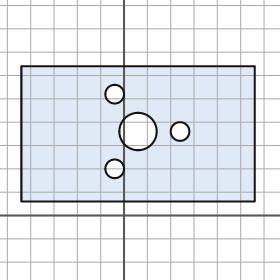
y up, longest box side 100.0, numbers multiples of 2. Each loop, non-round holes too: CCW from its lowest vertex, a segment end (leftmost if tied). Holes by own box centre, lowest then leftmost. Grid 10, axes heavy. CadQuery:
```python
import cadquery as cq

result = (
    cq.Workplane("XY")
    .moveTo(-44.0, 6.0)
    .lineTo(56.0, 6.0)
    .lineTo(56.0, 64.0)
    .lineTo(-44.0, 64.0)
    .close()
    .moveTo(-4.0, 20.0)
    .circle(4.0)
    .moveTo(6.0, 36.0)
    .circle(8.0)
    .moveTo(24.0, 36.0)
    .circle(4.0)
    .moveTo(-4.0, 52.0)
    .circle(4.0)
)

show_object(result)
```